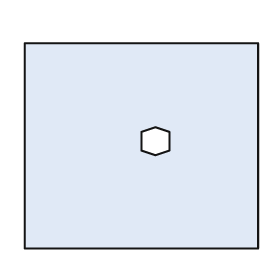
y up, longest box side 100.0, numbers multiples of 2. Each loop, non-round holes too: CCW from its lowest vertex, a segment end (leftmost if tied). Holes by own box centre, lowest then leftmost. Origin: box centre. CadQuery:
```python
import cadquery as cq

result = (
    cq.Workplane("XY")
    .moveTo(-50.0, -44.0)
    .lineTo(50.0, -44.0)
    .lineTo(50.0, 44.0)
    .lineTo(-50.0, 44.0)
    .close()
    .moveTo(6.0, -4.0)
    .lineTo(12.0, -2.0)
    .lineTo(12.0, 6.0)
    .lineTo(6.0, 8.0)
    .lineTo(0.0, 6.0)
    .lineTo(0.0, -2.0)
    .close()
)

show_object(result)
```